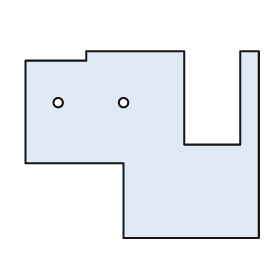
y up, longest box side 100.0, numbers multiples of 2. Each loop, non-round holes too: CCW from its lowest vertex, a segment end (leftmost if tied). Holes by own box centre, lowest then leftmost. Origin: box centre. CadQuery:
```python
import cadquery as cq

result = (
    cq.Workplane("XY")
    .moveTo(-8.0, -40.0)
    .lineTo(50.0, -40.0)
    .lineTo(50.0, 40.0)
    .lineTo(42.0, 40.0)
    .lineTo(42.0, 0.0)
    .lineTo(18.0, 0.0)
    .lineTo(18.0, 40.0)
    .lineTo(-24.0, 40.0)
    .lineTo(-24.0, 36.0)
    .lineTo(-50.0, 36.0)
    .lineTo(-50.0, -8.0)
    .lineTo(-8.0, -8.0)
    .close()
    .moveTo(-36.0, 18.0)
    .circle(2.0)
    .moveTo(-8.0, 18.0)
    .circle(2.0)
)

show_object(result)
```